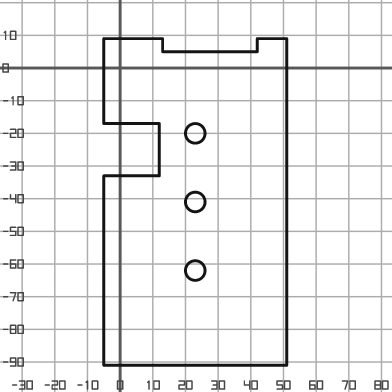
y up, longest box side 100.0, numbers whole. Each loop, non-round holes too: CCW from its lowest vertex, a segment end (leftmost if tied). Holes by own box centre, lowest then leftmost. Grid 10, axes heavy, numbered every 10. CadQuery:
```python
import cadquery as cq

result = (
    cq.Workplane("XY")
    .moveTo(-5.0, -91.0)
    .lineTo(51.0, -91.0)
    .lineTo(51.0, 9.0)
    .lineTo(42.0, 9.0)
    .lineTo(42.0, 5.0)
    .lineTo(13.0, 5.0)
    .lineTo(13.0, 9.0)
    .lineTo(-5.0, 9.0)
    .lineTo(-5.0, -17.0)
    .lineTo(12.0, -17.0)
    .lineTo(12.0, -33.0)
    .lineTo(-5.0, -33.0)
    .close()
    .moveTo(23.0, -62.0)
    .circle(3.0)
    .moveTo(23.0, -41.0)
    .circle(3.0)
    .moveTo(23.0, -20.0)
    .circle(3.0)
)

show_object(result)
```